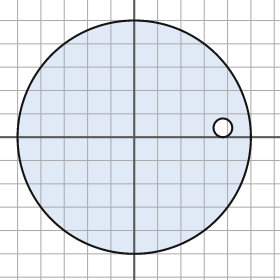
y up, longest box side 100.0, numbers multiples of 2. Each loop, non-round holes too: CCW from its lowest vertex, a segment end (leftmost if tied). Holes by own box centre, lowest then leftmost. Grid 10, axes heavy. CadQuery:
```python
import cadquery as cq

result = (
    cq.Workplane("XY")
    .moveTo(0.0, 0.0)
    .circle(50.0)
    .moveTo(38.0, 4.0)
    .circle(4.0)
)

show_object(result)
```